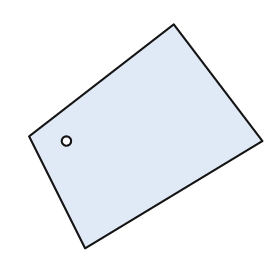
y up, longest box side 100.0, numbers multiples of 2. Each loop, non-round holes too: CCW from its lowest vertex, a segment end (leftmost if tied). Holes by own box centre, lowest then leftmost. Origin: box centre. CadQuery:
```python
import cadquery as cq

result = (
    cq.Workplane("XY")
    .moveTo(-26.0, -48.0)
    .lineTo(50.0, -2.0)
    .lineTo(12.0, 48.0)
    .lineTo(-50.0, 0.0)
    .close()
    .moveTo(-34.0, -2.0)
    .circle(2.0)
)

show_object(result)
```